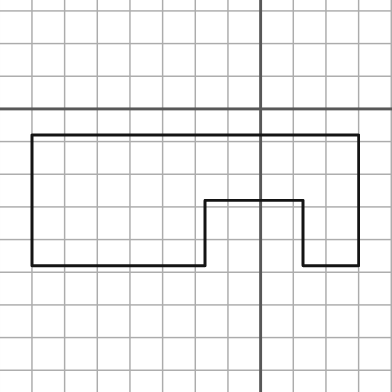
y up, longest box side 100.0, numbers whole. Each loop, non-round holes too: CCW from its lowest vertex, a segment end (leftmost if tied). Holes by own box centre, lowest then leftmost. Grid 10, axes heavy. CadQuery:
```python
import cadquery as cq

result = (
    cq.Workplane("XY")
    .moveTo(-70.0, -48.0)
    .lineTo(-17.0, -48.0)
    .lineTo(-17.0, -28.0)
    .lineTo(13.0, -28.0)
    .lineTo(13.0, -48.0)
    .lineTo(30.0, -48.0)
    .lineTo(30.0, -8.0)
    .lineTo(-70.0, -8.0)
    .close()
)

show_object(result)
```